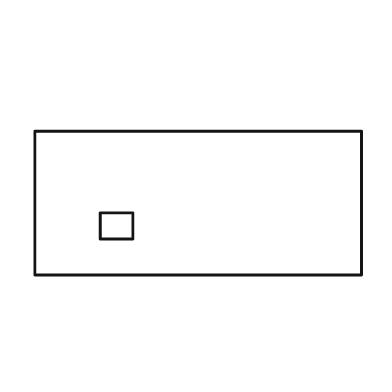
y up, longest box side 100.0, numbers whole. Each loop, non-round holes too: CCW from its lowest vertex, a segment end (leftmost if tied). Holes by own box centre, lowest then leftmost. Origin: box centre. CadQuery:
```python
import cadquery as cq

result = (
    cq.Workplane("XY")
    .moveTo(-50.0, -22.0)
    .lineTo(50.0, -22.0)
    .lineTo(50.0, 22.0)
    .lineTo(-50.0, 22.0)
    .close()
    .moveTo(-30.0, -11.0)
    .lineTo(-20.0, -11.0)
    .lineTo(-20.0, -3.0)
    .lineTo(-30.0, -3.0)
    .close()
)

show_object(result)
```